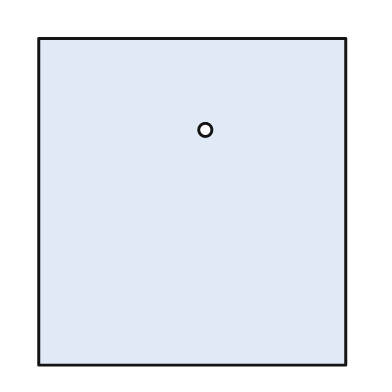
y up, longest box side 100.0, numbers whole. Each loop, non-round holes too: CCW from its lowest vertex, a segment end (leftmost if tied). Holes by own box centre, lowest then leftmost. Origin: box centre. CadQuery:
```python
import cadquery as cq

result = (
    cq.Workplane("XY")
    .moveTo(-47.0, -50.0)
    .lineTo(47.0, -50.0)
    .lineTo(47.0, 50.0)
    .lineTo(-47.0, 50.0)
    .close()
    .moveTo(4.0, 22.0)
    .circle(2.0)
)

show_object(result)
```